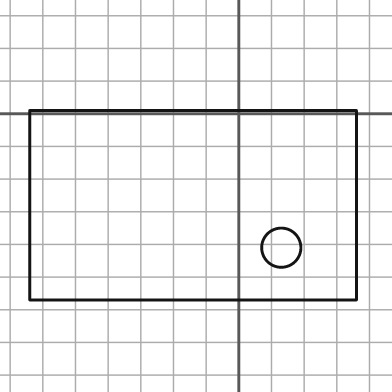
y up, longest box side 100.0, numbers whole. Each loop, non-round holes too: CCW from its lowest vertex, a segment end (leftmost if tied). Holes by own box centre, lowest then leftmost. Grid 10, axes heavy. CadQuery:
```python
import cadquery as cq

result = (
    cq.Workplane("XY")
    .moveTo(-64.0, -57.0)
    .lineTo(36.0, -57.0)
    .lineTo(36.0, 1.0)
    .lineTo(-64.0, 1.0)
    .close()
    .moveTo(13.0, -41.0)
    .circle(6.0)
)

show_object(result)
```